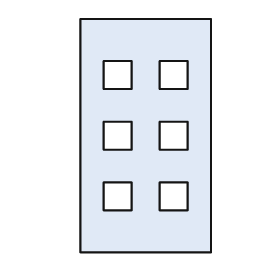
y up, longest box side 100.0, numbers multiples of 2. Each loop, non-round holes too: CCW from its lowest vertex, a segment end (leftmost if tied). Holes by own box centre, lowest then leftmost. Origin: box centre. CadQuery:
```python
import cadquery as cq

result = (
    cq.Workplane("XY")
    .moveTo(-28.0, -50.0)
    .lineTo(28.0, -50.0)
    .lineTo(28.0, 50.0)
    .lineTo(-28.0, 50.0)
    .close()
    .moveTo(-18.0, -32.0)
    .lineTo(-6.0, -32.0)
    .lineTo(-6.0, -20.0)
    .lineTo(-18.0, -20.0)
    .close()
    .moveTo(6.0, -32.0)
    .lineTo(18.0, -32.0)
    .lineTo(18.0, -20.0)
    .lineTo(6.0, -20.0)
    .close()
    .moveTo(-18.0, -6.0)
    .lineTo(-6.0, -6.0)
    .lineTo(-6.0, 6.0)
    .lineTo(-18.0, 6.0)
    .close()
    .moveTo(6.0, -6.0)
    .lineTo(18.0, -6.0)
    .lineTo(18.0, 6.0)
    .lineTo(6.0, 6.0)
    .close()
    .moveTo(-18.0, 20.0)
    .lineTo(-6.0, 20.0)
    .lineTo(-6.0, 32.0)
    .lineTo(-18.0, 32.0)
    .close()
    .moveTo(6.0, 20.0)
    .lineTo(18.0, 20.0)
    .lineTo(18.0, 32.0)
    .lineTo(6.0, 32.0)
    .close()
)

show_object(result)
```